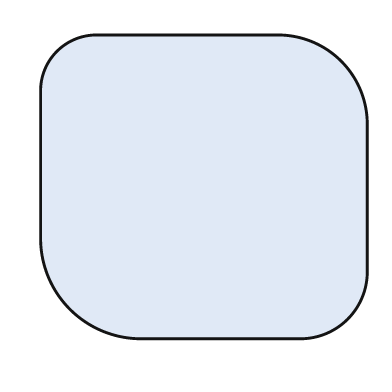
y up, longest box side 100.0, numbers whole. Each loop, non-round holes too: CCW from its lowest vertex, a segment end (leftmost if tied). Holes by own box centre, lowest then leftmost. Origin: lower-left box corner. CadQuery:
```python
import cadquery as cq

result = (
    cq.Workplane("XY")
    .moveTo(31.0, 0.0)
    .lineTo(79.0, 0.0)
    .threePointArc((94.0, 6.0), (100.0, 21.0))
    .lineTo(100.0, 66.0)
    .threePointArc((92.0, 85.0), (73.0, 93.0))
    .lineTo(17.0, 93.0)
    .threePointArc((5.0, 88.0), (0.0, 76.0))
    .lineTo(0.0, 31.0)
    .threePointArc((9.0, 9.0), (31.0, 0.0))
    .close()
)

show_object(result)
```